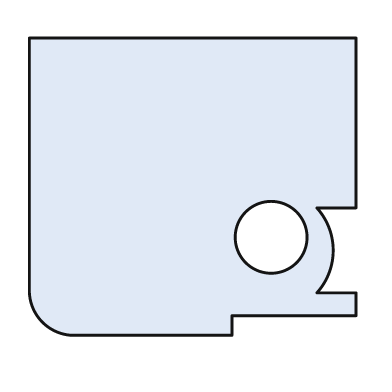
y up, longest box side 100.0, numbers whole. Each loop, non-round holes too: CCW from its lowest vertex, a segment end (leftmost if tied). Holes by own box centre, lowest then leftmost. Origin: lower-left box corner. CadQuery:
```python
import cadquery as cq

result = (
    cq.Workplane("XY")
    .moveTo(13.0, 0.0)
    .lineTo(62.0, 0.0)
    .lineTo(62.0, 6.0)
    .lineTo(100.0, 6.0)
    .lineTo(100.0, 13.0)
    .lineTo(88.0, 13.0)
    .threePointArc((93.0, 26.0), (88.0, 39.0))
    .lineTo(100.0, 39.0)
    .lineTo(100.0, 91.0)
    .lineTo(0.0, 91.0)
    .lineTo(0.0, 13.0)
    .threePointArc((4.0, 4.0), (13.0, 0.0))
    .close()
    .moveTo(74.0, 30.0)
    .circle(11.0)
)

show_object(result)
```